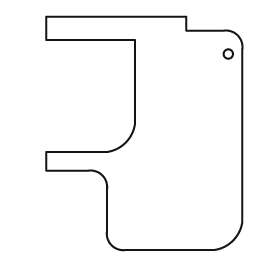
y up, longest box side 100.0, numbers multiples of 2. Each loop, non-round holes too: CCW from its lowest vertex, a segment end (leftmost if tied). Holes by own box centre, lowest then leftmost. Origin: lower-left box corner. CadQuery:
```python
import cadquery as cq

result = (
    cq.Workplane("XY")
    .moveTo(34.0, 0.0)
    .lineTo(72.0, 0.0)
    .threePointArc((80.0, 4.0), (84.0, 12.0))
    .lineTo(84.0, 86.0)
    .threePointArc((82.0, 92.0), (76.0, 94.0))
    .lineTo(60.0, 94.0)
    .lineTo(60.0, 100.0)
    .lineTo(0.0, 100.0)
    .lineTo(0.0, 90.0)
    .lineTo(38.0, 90.0)
    .lineTo(38.0, 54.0)
    .threePointArc((34.0, 46.0), (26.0, 42.0))
    .lineTo(0.0, 42.0)
    .lineTo(0.0, 34.0)
    .lineTo(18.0, 34.0)
    .threePointArc((24.0, 32.0), (26.0, 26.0))
    .lineTo(26.0, 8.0)
    .threePointArc((28.0, 2.0), (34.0, 0.0))
    .close()
    .moveTo(78.0, 84.0)
    .circle(2.0)
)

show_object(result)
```